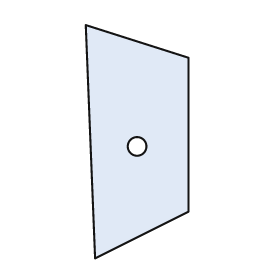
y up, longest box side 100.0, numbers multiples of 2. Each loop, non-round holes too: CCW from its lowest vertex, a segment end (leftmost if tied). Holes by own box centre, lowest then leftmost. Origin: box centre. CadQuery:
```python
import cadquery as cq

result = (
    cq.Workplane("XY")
    .moveTo(-18.0, -50.0)
    .lineTo(22.0, -30.0)
    .lineTo(22.0, 36.0)
    .lineTo(-22.0, 50.0)
    .close()
    .moveTo(0.0, -2.0)
    .circle(4.0)
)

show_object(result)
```